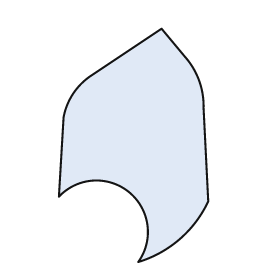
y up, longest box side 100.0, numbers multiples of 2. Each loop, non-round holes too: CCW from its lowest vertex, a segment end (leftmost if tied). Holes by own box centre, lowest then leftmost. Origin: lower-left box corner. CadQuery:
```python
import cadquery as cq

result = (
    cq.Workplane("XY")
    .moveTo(34.0, 0.0)
    .threePointArc((52.0, 10.0), (64.0, 26.0))
    .lineTo(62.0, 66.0)
    .threePointArc((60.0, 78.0), (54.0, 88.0))
    .lineTo(44.0, 100.0)
    .lineTo(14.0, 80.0)
    .threePointArc((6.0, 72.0), (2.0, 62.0))
    .lineTo(0.0, 28.0)
    .threePointArc((30.0, 30.0), (34.0, 0.0))
    .close()
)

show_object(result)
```